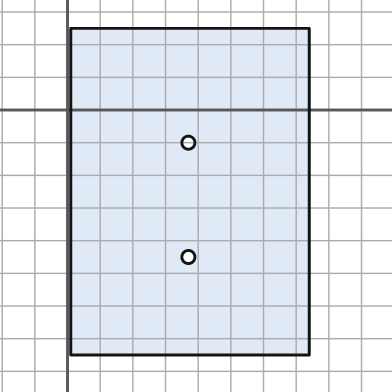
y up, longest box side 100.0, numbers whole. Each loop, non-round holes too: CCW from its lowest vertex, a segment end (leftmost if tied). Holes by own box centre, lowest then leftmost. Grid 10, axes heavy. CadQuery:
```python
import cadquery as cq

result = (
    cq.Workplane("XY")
    .moveTo(1.0, -75.0)
    .lineTo(74.0, -75.0)
    .lineTo(74.0, 25.0)
    .lineTo(1.0, 25.0)
    .close()
    .moveTo(37.0, -45.0)
    .circle(2.0)
    .moveTo(37.0, -10.0)
    .circle(2.0)
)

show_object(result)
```